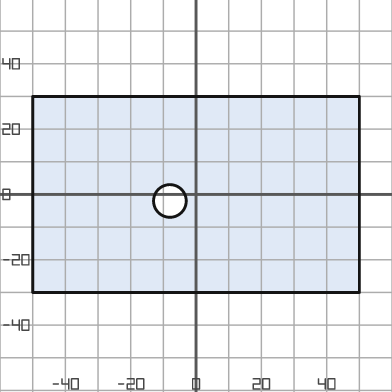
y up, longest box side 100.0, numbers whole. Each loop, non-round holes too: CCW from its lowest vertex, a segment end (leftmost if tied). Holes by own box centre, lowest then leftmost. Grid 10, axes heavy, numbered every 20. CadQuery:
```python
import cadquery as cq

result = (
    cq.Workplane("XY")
    .moveTo(-50.0, -30.0)
    .lineTo(50.0, -30.0)
    .lineTo(50.0, 30.0)
    .lineTo(-50.0, 30.0)
    .close()
    .moveTo(-8.0, -2.0)
    .circle(5.0)
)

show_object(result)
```